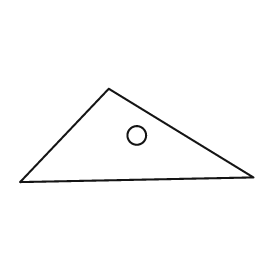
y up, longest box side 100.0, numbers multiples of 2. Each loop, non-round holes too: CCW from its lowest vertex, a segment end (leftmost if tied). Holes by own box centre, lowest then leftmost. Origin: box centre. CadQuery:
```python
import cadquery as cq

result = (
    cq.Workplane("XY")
    .moveTo(-50.0, -20.0)
    .lineTo(50.0, -18.0)
    .lineTo(-12.0, 20.0)
    .close()
    .moveTo(0.0, 0.0)
    .circle(4.0)
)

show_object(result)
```